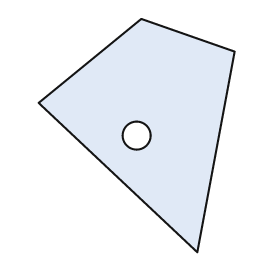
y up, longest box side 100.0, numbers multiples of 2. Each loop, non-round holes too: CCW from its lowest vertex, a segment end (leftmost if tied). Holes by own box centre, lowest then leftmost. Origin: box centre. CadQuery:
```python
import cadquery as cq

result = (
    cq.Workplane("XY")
    .moveTo(26.0, -50.0)
    .lineTo(42.0, 36.0)
    .lineTo(2.0, 50.0)
    .lineTo(-42.0, 14.0)
    .close()
    .moveTo(0.0, 0.0)
    .circle(6.0)
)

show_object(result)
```